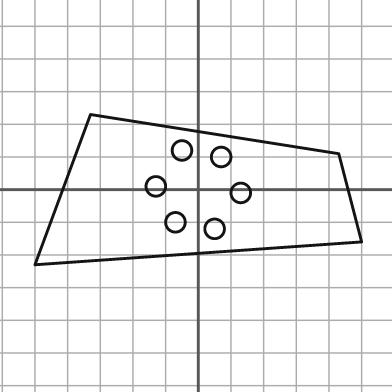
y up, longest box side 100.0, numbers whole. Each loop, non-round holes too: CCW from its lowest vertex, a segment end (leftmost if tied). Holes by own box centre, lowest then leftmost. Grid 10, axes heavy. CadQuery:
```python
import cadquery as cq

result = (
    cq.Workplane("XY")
    .moveTo(-50.0, -23.0)
    .lineTo(50.0, -16.0)
    .lineTo(43.0, 11.0)
    .lineTo(-33.0, 23.0)
    .close()
    .moveTo(5.0, -12.0)
    .circle(3.0)
    .moveTo(-7.0, -10.0)
    .circle(3.0)
    .moveTo(13.0, -1.0)
    .circle(3.0)
    .moveTo(-13.0, 1.0)
    .circle(3.0)
    .moveTo(7.0, 10.0)
    .circle(3.0)
    .moveTo(-5.0, 12.0)
    .circle(3.0)
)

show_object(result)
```